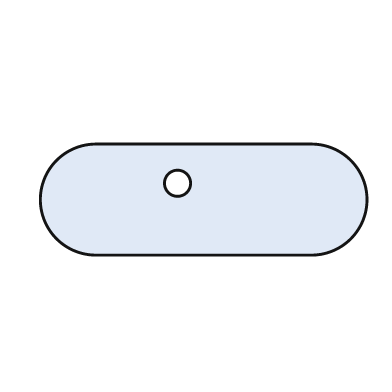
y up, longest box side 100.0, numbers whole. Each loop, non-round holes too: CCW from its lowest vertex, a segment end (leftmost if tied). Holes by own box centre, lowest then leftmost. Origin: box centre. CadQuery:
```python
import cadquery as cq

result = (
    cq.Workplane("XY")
    .moveTo(-33.0, -17.0)
    .lineTo(33.0, -17.0)
    .threePointArc((50.0, 0.0), (33.0, 17.0))
    .lineTo(-33.0, 17.0)
    .threePointArc((-50.0, 0.0), (-33.0, -17.0))
    .close()
    .moveTo(-8.0, 5.0)
    .circle(4.0)
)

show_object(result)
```